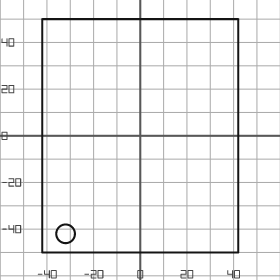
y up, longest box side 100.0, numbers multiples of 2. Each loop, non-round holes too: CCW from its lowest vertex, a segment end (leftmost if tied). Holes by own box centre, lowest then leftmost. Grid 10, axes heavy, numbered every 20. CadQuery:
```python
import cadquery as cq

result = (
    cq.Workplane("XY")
    .moveTo(-42.0, -50.0)
    .lineTo(42.0, -50.0)
    .lineTo(42.0, 50.0)
    .lineTo(-42.0, 50.0)
    .close()
    .moveTo(-32.0, -42.0)
    .circle(4.0)
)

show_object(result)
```